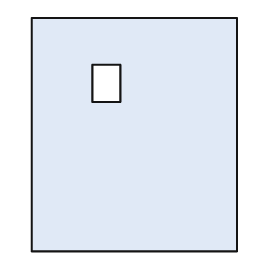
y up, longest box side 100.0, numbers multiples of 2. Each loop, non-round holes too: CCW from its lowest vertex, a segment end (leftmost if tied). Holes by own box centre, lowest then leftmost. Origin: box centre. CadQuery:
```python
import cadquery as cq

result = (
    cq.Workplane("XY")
    .moveTo(-44.0, -50.0)
    .lineTo(44.0, -50.0)
    .lineTo(44.0, 50.0)
    .lineTo(-44.0, 50.0)
    .close()
    .moveTo(-18.0, 14.0)
    .lineTo(-6.0, 14.0)
    .lineTo(-6.0, 30.0)
    .lineTo(-18.0, 30.0)
    .close()
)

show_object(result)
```